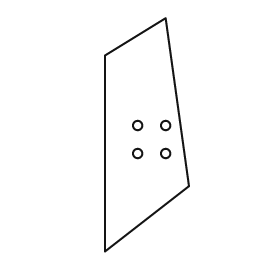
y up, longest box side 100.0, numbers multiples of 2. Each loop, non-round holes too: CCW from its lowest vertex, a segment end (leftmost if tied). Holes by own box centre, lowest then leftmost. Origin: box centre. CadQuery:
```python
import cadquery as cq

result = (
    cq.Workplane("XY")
    .moveTo(-18.0, -50.0)
    .lineTo(18.0, -22.0)
    .lineTo(8.0, 50.0)
    .lineTo(-18.0, 34.0)
    .close()
    .moveTo(-4.0, -8.0)
    .circle(2.0)
    .moveTo(8.0, -8.0)
    .circle(2.0)
    .moveTo(-4.0, 4.0)
    .circle(2.0)
    .moveTo(8.0, 4.0)
    .circle(2.0)
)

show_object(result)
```